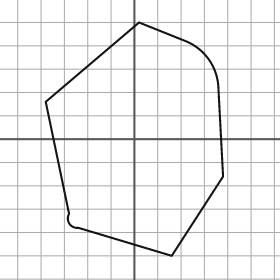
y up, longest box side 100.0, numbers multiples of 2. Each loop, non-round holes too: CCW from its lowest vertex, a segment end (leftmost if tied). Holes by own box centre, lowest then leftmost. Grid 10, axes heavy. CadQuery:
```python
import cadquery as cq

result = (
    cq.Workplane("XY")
    .moveTo(16.0, -50.0)
    .lineTo(38.0, -16.0)
    .lineTo(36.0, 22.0)
    .threePointArc((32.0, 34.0), (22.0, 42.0))
    .lineTo(2.0, 50.0)
    .lineTo(-38.0, 16.0)
    .lineTo(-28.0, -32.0)
    .threePointArc((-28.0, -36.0), (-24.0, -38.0))
    .close()
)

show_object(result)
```